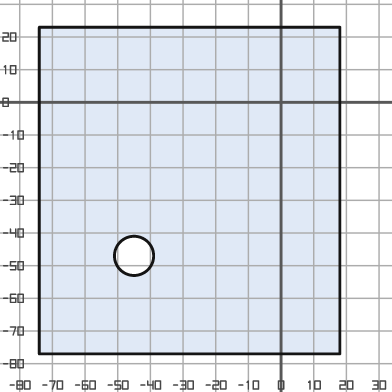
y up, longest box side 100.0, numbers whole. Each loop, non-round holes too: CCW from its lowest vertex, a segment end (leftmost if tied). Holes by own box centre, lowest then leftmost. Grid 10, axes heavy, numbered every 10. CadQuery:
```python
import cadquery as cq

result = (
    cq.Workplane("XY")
    .moveTo(-74.0, -77.0)
    .lineTo(18.0, -77.0)
    .lineTo(18.0, 23.0)
    .lineTo(-74.0, 23.0)
    .close()
    .moveTo(-45.0, -47.0)
    .circle(6.0)
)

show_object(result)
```